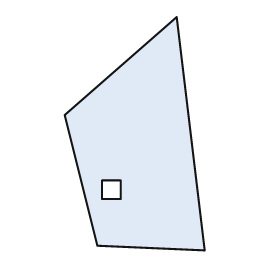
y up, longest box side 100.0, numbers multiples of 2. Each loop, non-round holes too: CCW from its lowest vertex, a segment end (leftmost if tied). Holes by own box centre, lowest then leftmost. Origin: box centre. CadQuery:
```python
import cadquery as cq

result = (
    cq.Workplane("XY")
    .moveTo(30.0, -50.0)
    .lineTo(18.0, 50.0)
    .lineTo(-30.0, 8.0)
    .lineTo(-16.0, -48.0)
    .close()
    .moveTo(-14.0, -28.0)
    .lineTo(-6.0, -28.0)
    .lineTo(-6.0, -20.0)
    .lineTo(-14.0, -20.0)
    .close()
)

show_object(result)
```